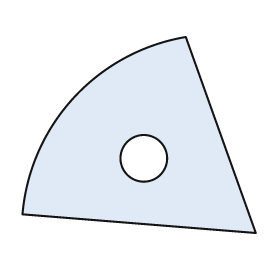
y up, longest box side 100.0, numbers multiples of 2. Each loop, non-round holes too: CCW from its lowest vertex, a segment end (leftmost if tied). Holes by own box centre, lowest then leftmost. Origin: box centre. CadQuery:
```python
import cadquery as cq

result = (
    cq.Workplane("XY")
    .moveTo(50.0, -42.0)
    .lineTo(20.0, 42.0)
    .threePointArc((-28.0, 16.0), (-50.0, -34.0))
    .close()
    .moveTo(2.0, -10.0)
    .circle(10.0)
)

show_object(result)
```